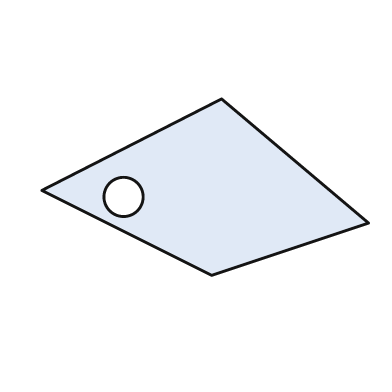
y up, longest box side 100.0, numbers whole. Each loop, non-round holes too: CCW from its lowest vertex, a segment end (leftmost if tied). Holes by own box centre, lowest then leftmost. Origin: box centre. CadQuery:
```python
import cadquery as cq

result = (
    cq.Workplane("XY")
    .moveTo(2.0, -27.0)
    .lineTo(50.0, -11.0)
    .lineTo(5.0, 27.0)
    .lineTo(-50.0, -1.0)
    .close()
    .moveTo(-25.0, -3.0)
    .circle(6.0)
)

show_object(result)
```